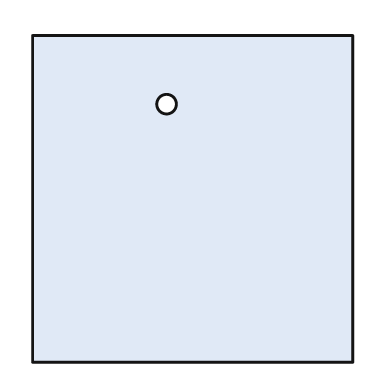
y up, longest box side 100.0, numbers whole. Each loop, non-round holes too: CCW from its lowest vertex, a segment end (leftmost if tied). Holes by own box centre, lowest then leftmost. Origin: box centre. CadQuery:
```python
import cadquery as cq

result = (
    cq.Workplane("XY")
    .moveTo(-49.0, -50.0)
    .lineTo(49.0, -50.0)
    .lineTo(49.0, 50.0)
    .lineTo(-49.0, 50.0)
    .close()
    .moveTo(-8.0, 29.0)
    .circle(3.0)
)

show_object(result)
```